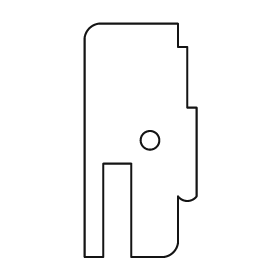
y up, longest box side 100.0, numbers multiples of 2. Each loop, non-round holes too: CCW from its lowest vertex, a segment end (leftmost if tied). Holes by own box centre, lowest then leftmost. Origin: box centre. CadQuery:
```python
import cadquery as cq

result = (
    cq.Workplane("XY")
    .moveTo(-24.0, -50.0)
    .lineTo(-16.0, -50.0)
    .lineTo(-16.0, -10.0)
    .lineTo(-4.0, -10.0)
    .lineTo(-4.0, -50.0)
    .lineTo(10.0, -50.0)
    .threePointArc((14.0, -48.0), (16.0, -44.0))
    .lineTo(16.0, -24.0)
    .threePointArc((20.0, -26.0), (24.0, -24.0))
    .lineTo(24.0, 14.0)
    .lineTo(20.0, 14.0)
    .lineTo(20.0, 40.0)
    .lineTo(16.0, 40.0)
    .lineTo(16.0, 50.0)
    .lineTo(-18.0, 50.0)
    .threePointArc((-22.0, 48.0), (-24.0, 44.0))
    .close()
    .moveTo(4.0, 0.0)
    .circle(4.0)
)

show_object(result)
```